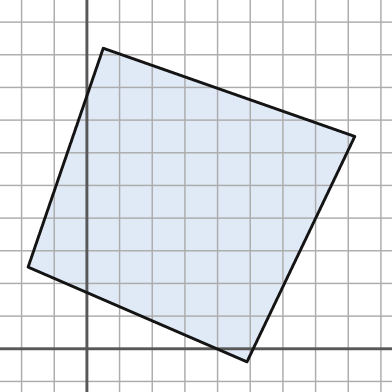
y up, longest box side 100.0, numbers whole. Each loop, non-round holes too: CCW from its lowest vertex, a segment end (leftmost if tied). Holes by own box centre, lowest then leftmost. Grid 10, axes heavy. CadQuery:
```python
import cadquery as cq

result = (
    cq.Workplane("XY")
    .moveTo(49.0, -4.0)
    .lineTo(82.0, 65.0)
    .lineTo(5.0, 92.0)
    .lineTo(-18.0, 25.0)
    .close()
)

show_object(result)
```